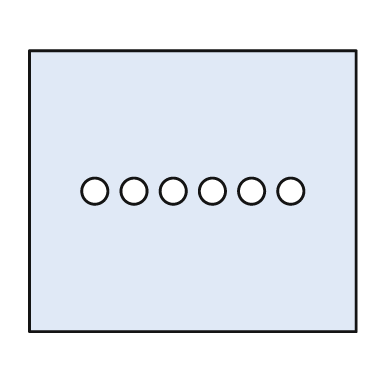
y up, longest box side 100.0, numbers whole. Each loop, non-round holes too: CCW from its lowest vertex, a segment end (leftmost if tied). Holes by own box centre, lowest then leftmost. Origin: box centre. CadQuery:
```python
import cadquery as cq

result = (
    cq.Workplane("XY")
    .moveTo(-50.0, -43.0)
    .lineTo(50.0, -43.0)
    .lineTo(50.0, 43.0)
    .lineTo(-50.0, 43.0)
    .close()
    .moveTo(-30.0, 0.0)
    .circle(4.0)
    .moveTo(-18.0, 0.0)
    .circle(4.0)
    .moveTo(-6.0, 0.0)
    .circle(4.0)
    .moveTo(6.0, 0.0)
    .circle(4.0)
    .moveTo(18.0, 0.0)
    .circle(4.0)
    .moveTo(30.0, 0.0)
    .circle(4.0)
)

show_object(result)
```